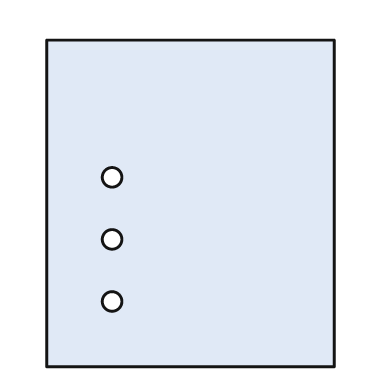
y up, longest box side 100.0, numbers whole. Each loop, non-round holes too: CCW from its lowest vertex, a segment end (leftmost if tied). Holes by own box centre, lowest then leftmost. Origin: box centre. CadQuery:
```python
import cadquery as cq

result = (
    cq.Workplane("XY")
    .moveTo(-44.0, -50.0)
    .lineTo(44.0, -50.0)
    .lineTo(44.0, 50.0)
    .lineTo(-44.0, 50.0)
    .close()
    .moveTo(-24.0, -30.0)
    .circle(3.0)
    .moveTo(-24.0, -11.0)
    .circle(3.0)
    .moveTo(-24.0, 8.0)
    .circle(3.0)
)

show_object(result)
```